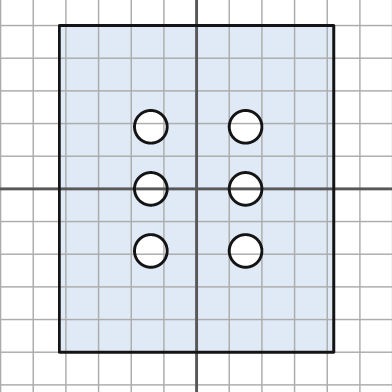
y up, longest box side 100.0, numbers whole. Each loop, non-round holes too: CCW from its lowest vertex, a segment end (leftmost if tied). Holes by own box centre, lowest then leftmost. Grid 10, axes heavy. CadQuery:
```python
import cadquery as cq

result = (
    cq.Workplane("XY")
    .moveTo(-42.0, -50.0)
    .lineTo(42.0, -50.0)
    .lineTo(42.0, 50.0)
    .lineTo(-42.0, 50.0)
    .close()
    .moveTo(-14.0, -19.0)
    .circle(5.0)
    .moveTo(15.0, -19.0)
    .circle(5.0)
    .moveTo(-14.0, 0.0)
    .circle(5.0)
    .moveTo(15.0, 0.0)
    .circle(5.0)
    .moveTo(-14.0, 19.0)
    .circle(5.0)
    .moveTo(15.0, 19.0)
    .circle(5.0)
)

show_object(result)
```